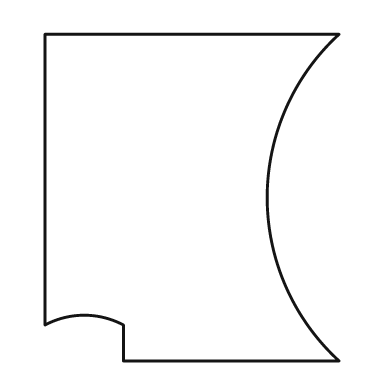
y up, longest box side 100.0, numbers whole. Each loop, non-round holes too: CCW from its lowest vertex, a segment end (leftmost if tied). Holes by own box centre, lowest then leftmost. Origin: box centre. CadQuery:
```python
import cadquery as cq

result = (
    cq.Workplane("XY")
    .moveTo(-21.0, -50.0)
    .lineTo(45.0, -50.0)
    .threePointArc((23.0, 0.0), (45.0, 50.0))
    .lineTo(-45.0, 50.0)
    .lineTo(-45.0, -39.0)
    .threePointArc((-33.0, -36.0), (-21.0, -39.0))
    .close()
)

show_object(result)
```